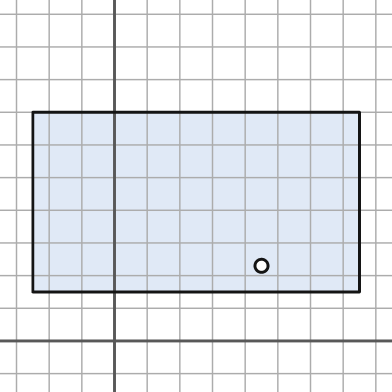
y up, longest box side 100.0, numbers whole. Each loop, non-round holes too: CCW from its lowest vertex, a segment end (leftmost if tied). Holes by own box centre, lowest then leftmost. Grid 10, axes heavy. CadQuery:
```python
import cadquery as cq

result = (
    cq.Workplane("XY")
    .moveTo(-25.0, 15.0)
    .lineTo(75.0, 15.0)
    .lineTo(75.0, 70.0)
    .lineTo(-25.0, 70.0)
    .close()
    .moveTo(45.0, 23.0)
    .circle(2.0)
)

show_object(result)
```